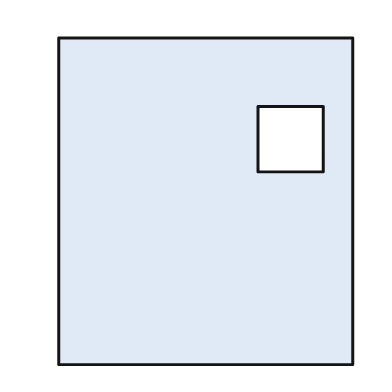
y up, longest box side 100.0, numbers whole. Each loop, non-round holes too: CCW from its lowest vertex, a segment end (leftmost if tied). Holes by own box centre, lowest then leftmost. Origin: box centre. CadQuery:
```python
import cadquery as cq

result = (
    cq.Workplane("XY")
    .moveTo(-45.0, -50.0)
    .lineTo(45.0, -50.0)
    .lineTo(45.0, 50.0)
    .lineTo(-45.0, 50.0)
    .close()
    .moveTo(16.0, 9.0)
    .lineTo(36.0, 9.0)
    .lineTo(36.0, 29.0)
    .lineTo(16.0, 29.0)
    .close()
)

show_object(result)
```